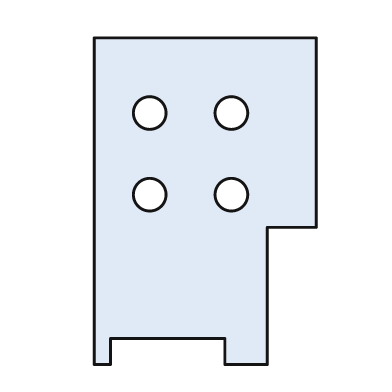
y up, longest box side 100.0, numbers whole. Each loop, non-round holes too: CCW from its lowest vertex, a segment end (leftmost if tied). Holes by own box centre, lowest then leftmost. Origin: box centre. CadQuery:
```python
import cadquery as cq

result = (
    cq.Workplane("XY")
    .moveTo(-34.0, -50.0)
    .lineTo(-29.0, -50.0)
    .lineTo(-29.0, -42.0)
    .lineTo(6.0, -42.0)
    .lineTo(6.0, -50.0)
    .lineTo(19.0, -50.0)
    .lineTo(19.0, -8.0)
    .lineTo(34.0, -8.0)
    .lineTo(34.0, 50.0)
    .lineTo(-34.0, 50.0)
    .close()
    .moveTo(-17.0, 2.0)
    .circle(5.0)
    .moveTo(8.0, 2.0)
    .circle(5.0)
    .moveTo(-17.0, 27.0)
    .circle(5.0)
    .moveTo(8.0, 27.0)
    .circle(5.0)
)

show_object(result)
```